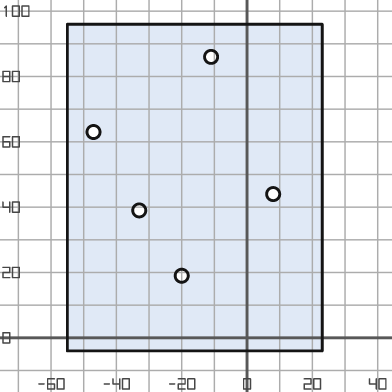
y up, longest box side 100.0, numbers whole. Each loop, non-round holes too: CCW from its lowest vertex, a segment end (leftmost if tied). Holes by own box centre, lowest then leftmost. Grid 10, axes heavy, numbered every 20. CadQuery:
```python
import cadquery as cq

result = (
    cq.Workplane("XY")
    .moveTo(-55.0, -4.0)
    .lineTo(23.0, -4.0)
    .lineTo(23.0, 96.0)
    .lineTo(-55.0, 96.0)
    .close()
    .moveTo(-20.0, 19.0)
    .circle(2.0)
    .moveTo(-33.0, 39.0)
    .circle(2.0)
    .moveTo(8.0, 44.0)
    .circle(2.0)
    .moveTo(-47.0, 63.0)
    .circle(2.0)
    .moveTo(-11.0, 86.0)
    .circle(2.0)
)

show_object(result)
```